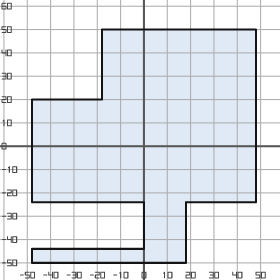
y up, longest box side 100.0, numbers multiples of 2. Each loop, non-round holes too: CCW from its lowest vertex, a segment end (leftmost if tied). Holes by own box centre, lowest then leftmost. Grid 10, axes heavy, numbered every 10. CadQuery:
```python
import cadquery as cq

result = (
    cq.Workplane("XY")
    .moveTo(-48.0, -50.0)
    .lineTo(18.0, -50.0)
    .lineTo(18.0, -24.0)
    .lineTo(48.0, -24.0)
    .lineTo(48.0, 50.0)
    .lineTo(-18.0, 50.0)
    .lineTo(-18.0, 20.0)
    .lineTo(-48.0, 20.0)
    .lineTo(-48.0, -24.0)
    .lineTo(0.0, -24.0)
    .lineTo(0.0, -44.0)
    .lineTo(-48.0, -44.0)
    .close()
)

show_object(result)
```